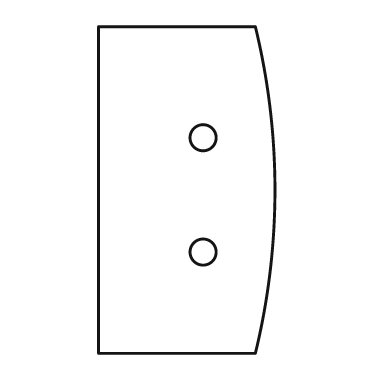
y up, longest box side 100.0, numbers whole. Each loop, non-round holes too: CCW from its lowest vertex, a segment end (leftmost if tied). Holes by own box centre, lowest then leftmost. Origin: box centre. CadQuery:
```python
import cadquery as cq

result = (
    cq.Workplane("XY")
    .moveTo(-27.0, -50.0)
    .lineTo(21.0, -50.0)
    .threePointArc((27.0, 0.0), (21.0, 50.0))
    .lineTo(-27.0, 50.0)
    .close()
    .moveTo(5.0, -19.0)
    .circle(4.0)
    .moveTo(5.0, 16.0)
    .circle(4.0)
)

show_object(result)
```